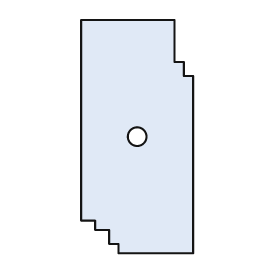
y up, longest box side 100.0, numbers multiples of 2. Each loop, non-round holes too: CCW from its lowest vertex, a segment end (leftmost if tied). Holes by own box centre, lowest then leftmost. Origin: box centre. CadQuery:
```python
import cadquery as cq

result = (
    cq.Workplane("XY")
    .moveTo(-8.0, -50.0)
    .lineTo(24.0, -50.0)
    .lineTo(24.0, 26.0)
    .lineTo(20.0, 26.0)
    .lineTo(20.0, 32.0)
    .lineTo(16.0, 32.0)
    .lineTo(16.0, 50.0)
    .lineTo(-24.0, 50.0)
    .lineTo(-24.0, -36.0)
    .lineTo(-18.0, -36.0)
    .lineTo(-18.0, -40.0)
    .lineTo(-12.0, -40.0)
    .lineTo(-12.0, -46.0)
    .lineTo(-8.0, -46.0)
    .close()
    .moveTo(0.0, 0.0)
    .circle(4.0)
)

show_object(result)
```